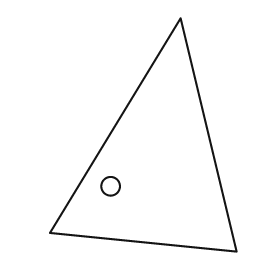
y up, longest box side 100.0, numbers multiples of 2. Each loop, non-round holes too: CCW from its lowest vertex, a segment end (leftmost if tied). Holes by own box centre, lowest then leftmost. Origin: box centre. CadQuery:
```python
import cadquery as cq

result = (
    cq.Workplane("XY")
    .moveTo(40.0, -50.0)
    .lineTo(16.0, 50.0)
    .lineTo(-40.0, -42.0)
    .close()
    .moveTo(-14.0, -22.0)
    .circle(4.0)
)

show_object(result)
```